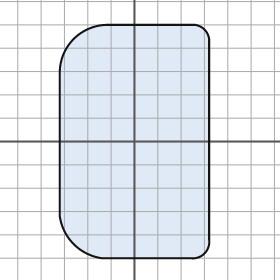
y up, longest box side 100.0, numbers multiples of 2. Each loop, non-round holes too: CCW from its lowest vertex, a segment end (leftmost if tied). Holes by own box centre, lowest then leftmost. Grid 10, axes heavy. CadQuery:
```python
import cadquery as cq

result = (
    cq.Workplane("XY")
    .moveTo(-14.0, -50.0)
    .lineTo(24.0, -50.0)
    .threePointArc((30.0, -48.0), (32.0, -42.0))
    .lineTo(32.0, 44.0)
    .threePointArc((30.0, 48.0), (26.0, 50.0))
    .lineTo(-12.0, 50.0)
    .threePointArc((-26.0, 44.0), (-32.0, 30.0))
    .lineTo(-32.0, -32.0)
    .threePointArc((-26.0, -44.0), (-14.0, -50.0))
    .close()
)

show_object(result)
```